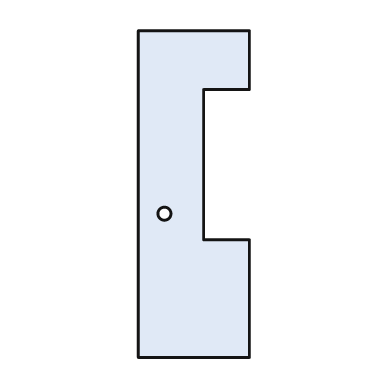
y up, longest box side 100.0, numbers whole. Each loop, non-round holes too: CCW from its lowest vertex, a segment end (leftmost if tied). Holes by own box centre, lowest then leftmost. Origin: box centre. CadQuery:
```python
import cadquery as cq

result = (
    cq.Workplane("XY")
    .moveTo(-17.0, -50.0)
    .lineTo(17.0, -50.0)
    .lineTo(17.0, -14.0)
    .lineTo(3.0, -14.0)
    .lineTo(3.0, 32.0)
    .lineTo(17.0, 32.0)
    .lineTo(17.0, 50.0)
    .lineTo(-17.0, 50.0)
    .close()
    .moveTo(-9.0, -6.0)
    .circle(2.0)
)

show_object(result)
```